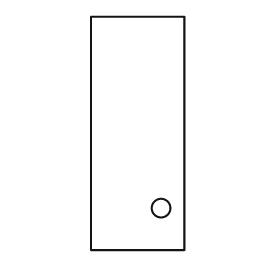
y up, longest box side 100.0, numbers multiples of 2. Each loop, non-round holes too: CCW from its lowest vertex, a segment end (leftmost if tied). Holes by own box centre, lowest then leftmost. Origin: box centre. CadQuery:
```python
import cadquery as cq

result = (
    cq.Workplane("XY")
    .moveTo(-20.0, -50.0)
    .lineTo(20.0, -50.0)
    .lineTo(20.0, 50.0)
    .lineTo(-20.0, 50.0)
    .close()
    .moveTo(10.0, -32.0)
    .circle(4.0)
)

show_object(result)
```